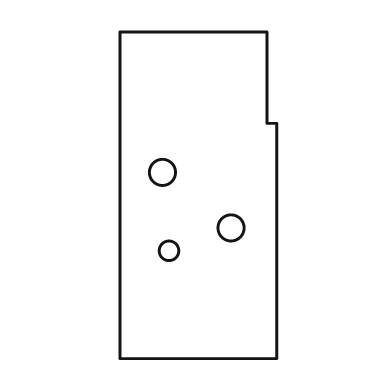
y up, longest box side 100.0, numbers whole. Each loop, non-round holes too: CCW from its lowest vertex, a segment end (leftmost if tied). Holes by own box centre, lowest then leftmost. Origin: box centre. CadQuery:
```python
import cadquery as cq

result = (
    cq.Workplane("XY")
    .moveTo(-24.0, -50.0)
    .lineTo(24.0, -50.0)
    .lineTo(24.0, 22.0)
    .lineTo(21.0, 22.0)
    .lineTo(21.0, 50.0)
    .lineTo(-24.0, 50.0)
    .close()
    .moveTo(-9.0, -17.0)
    .circle(3.0)
    .moveTo(10.0, -10.0)
    .circle(4.0)
    .moveTo(-11.0, 7.0)
    .circle(4.0)
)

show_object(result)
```